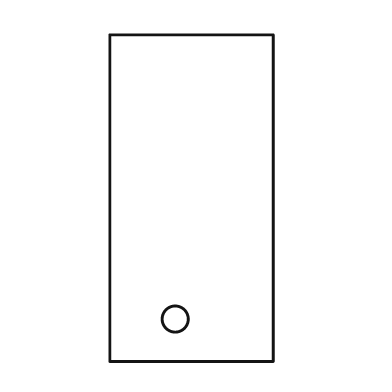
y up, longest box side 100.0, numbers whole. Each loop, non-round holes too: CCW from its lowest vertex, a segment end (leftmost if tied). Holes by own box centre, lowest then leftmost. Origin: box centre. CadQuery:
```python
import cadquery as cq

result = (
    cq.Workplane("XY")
    .moveTo(-25.0, -50.0)
    .lineTo(25.0, -50.0)
    .lineTo(25.0, 50.0)
    .lineTo(-25.0, 50.0)
    .close()
    .moveTo(-5.0, -37.0)
    .circle(4.0)
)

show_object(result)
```